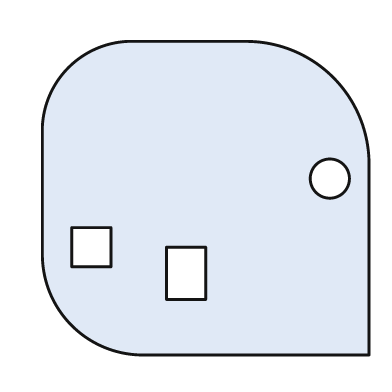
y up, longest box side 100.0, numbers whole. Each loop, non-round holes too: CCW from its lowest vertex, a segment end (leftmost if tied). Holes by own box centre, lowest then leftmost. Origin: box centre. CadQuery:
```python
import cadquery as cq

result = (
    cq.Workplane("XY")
    .moveTo(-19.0, -48.0)
    .lineTo(50.0, -48.0)
    .lineTo(50.0, 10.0)
    .threePointArc((39.0, 37.0), (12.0, 48.0))
    .lineTo(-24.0, 48.0)
    .threePointArc((-42.0, 40.0), (-50.0, 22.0))
    .lineTo(-50.0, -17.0)
    .threePointArc((-41.0, -39.0), (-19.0, -48.0))
    .close()
    .moveTo(-12.0, -31.0)
    .lineTo(0.0, -31.0)
    .lineTo(0.0, -15.0)
    .lineTo(-12.0, -15.0)
    .close()
    .moveTo(-41.0, -21.0)
    .lineTo(-29.0, -21.0)
    .lineTo(-29.0, -9.0)
    .lineTo(-41.0, -9.0)
    .close()
    .moveTo(38.0, 6.0)
    .circle(6.0)
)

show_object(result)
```